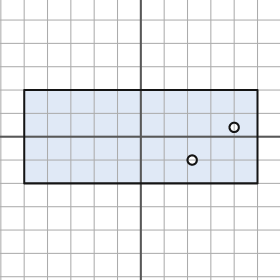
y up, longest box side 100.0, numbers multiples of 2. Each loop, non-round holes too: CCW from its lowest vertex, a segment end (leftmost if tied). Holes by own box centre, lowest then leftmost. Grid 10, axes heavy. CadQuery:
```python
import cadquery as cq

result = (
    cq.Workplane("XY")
    .moveTo(-50.0, -20.0)
    .lineTo(50.0, -20.0)
    .lineTo(50.0, 20.0)
    .lineTo(-50.0, 20.0)
    .close()
    .moveTo(22.0, -10.0)
    .circle(2.0)
    .moveTo(40.0, 4.0)
    .circle(2.0)
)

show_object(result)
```